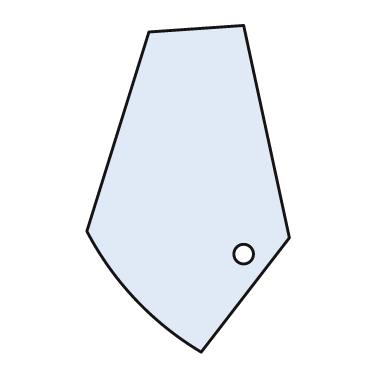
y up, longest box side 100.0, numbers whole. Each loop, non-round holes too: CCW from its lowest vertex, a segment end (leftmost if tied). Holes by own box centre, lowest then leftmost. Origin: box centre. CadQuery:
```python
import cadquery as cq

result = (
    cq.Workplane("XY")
    .moveTo(4.0, -50.0)
    .lineTo(31.0, -15.0)
    .lineTo(17.0, 50.0)
    .lineTo(-12.0, 48.0)
    .lineTo(-31.0, -13.0)
    .threePointArc((-16.0, -34.0), (4.0, -50.0))
    .close()
    .moveTo(17.0, -20.0)
    .circle(3.0)
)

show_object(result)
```